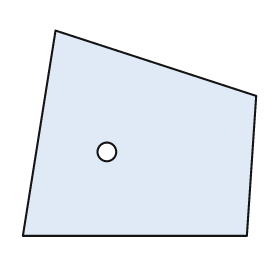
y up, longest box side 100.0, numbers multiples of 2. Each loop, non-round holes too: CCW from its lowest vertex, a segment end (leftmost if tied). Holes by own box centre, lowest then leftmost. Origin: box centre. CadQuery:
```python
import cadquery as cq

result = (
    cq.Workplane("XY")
    .moveTo(-50.0, -44.0)
    .lineTo(46.0, -44.0)
    .lineTo(50.0, 16.0)
    .lineTo(-36.0, 44.0)
    .close()
    .moveTo(-14.0, -8.0)
    .circle(4.0)
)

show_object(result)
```